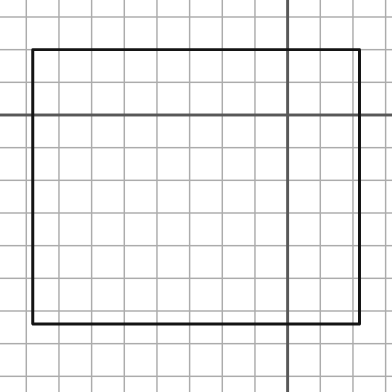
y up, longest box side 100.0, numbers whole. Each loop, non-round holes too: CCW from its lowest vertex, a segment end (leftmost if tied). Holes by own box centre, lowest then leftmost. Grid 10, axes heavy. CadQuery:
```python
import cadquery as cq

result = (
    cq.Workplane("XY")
    .moveTo(-78.0, -64.0)
    .lineTo(22.0, -64.0)
    .lineTo(22.0, 20.0)
    .lineTo(-78.0, 20.0)
    .close()
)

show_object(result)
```